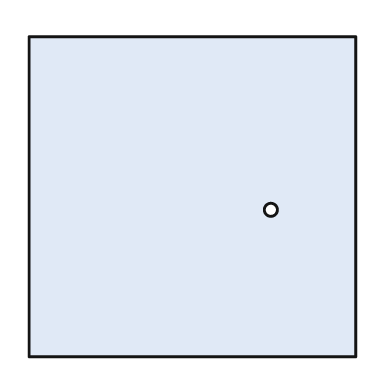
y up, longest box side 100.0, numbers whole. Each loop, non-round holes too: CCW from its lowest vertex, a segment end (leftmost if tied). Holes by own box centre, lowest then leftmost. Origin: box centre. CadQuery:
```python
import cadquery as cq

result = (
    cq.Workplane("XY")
    .moveTo(-50.0, -49.0)
    .lineTo(50.0, -49.0)
    .lineTo(50.0, 49.0)
    .lineTo(-50.0, 49.0)
    .close()
    .moveTo(24.0, -4.0)
    .circle(2.0)
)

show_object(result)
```